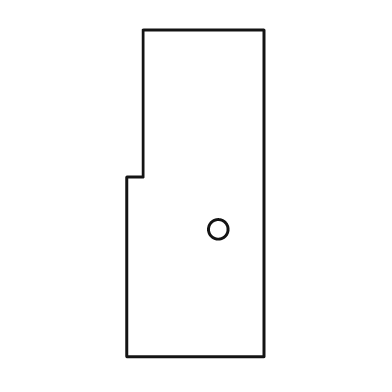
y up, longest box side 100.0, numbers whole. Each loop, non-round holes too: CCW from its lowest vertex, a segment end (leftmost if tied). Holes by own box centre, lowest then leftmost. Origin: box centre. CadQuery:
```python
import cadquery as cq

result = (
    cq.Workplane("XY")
    .moveTo(-21.0, -50.0)
    .lineTo(21.0, -50.0)
    .lineTo(21.0, 50.0)
    .lineTo(-16.0, 50.0)
    .lineTo(-16.0, 5.0)
    .lineTo(-21.0, 5.0)
    .close()
    .moveTo(7.0, -11.0)
    .circle(3.0)
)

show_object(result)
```